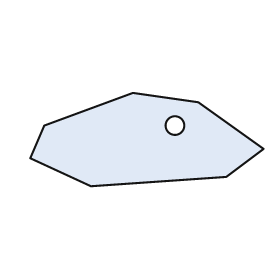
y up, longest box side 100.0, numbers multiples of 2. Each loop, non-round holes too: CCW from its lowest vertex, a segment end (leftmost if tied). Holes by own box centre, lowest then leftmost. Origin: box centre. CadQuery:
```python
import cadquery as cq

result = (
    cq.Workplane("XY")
    .moveTo(-24.0, -20.0)
    .lineTo(34.0, -16.0)
    .lineTo(50.0, -4.0)
    .lineTo(22.0, 16.0)
    .lineTo(-6.0, 20.0)
    .lineTo(-44.0, 6.0)
    .lineTo(-50.0, -8.0)
    .close()
    .moveTo(12.0, 6.0)
    .circle(4.0)
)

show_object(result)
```